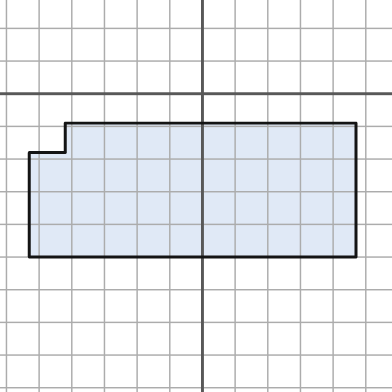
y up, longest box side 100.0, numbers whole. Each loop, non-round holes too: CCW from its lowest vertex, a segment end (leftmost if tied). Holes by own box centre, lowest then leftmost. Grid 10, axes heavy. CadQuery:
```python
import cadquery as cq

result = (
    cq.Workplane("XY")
    .moveTo(-53.0, -50.0)
    .lineTo(47.0, -50.0)
    .lineTo(47.0, -9.0)
    .lineTo(-42.0, -9.0)
    .lineTo(-42.0, -18.0)
    .lineTo(-53.0, -18.0)
    .close()
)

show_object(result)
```